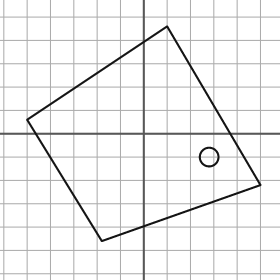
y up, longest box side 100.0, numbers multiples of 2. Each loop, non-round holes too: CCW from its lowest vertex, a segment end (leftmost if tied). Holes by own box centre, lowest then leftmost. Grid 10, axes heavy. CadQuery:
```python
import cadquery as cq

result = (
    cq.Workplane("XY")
    .moveTo(-18.0, -46.0)
    .lineTo(50.0, -22.0)
    .lineTo(10.0, 46.0)
    .lineTo(-50.0, 6.0)
    .close()
    .moveTo(28.0, -10.0)
    .circle(4.0)
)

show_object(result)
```